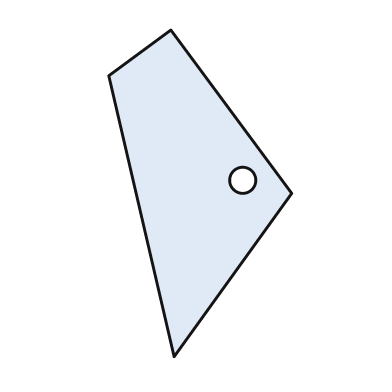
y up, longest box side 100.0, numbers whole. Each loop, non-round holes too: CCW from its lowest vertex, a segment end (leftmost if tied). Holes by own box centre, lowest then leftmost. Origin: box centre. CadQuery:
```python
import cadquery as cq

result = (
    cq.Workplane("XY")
    .moveTo(-8.0, -50.0)
    .lineTo(28.0, 0.0)
    .lineTo(-9.0, 50.0)
    .lineTo(-28.0, 36.0)
    .close()
    .moveTo(13.0, 4.0)
    .circle(4.0)
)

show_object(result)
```